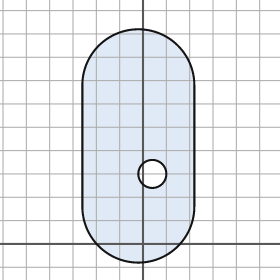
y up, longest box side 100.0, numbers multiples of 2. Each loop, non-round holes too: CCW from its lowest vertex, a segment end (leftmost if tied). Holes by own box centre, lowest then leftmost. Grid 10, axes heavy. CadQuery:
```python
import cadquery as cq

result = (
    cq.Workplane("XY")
    .moveTo(-26.0, 16.0)
    .threePointArc((-2.0, -8.0), (22.0, 16.0))
    .lineTo(22.0, 68.0)
    .threePointArc((-2.0, 92.0), (-26.0, 68.0))
    .close()
    .moveTo(4.0, 30.0)
    .circle(6.0)
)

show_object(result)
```